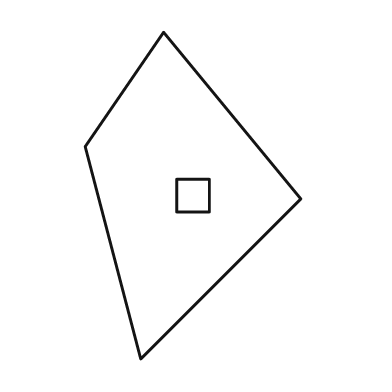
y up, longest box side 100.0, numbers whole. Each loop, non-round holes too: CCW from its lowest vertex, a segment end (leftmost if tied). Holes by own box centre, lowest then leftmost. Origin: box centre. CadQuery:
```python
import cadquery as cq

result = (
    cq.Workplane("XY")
    .moveTo(-16.0, -50.0)
    .lineTo(33.0, -1.0)
    .lineTo(-9.0, 50.0)
    .lineTo(-33.0, 15.0)
    .close()
    .moveTo(-5.0, -5.0)
    .lineTo(5.0, -5.0)
    .lineTo(5.0, 5.0)
    .lineTo(-5.0, 5.0)
    .close()
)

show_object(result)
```